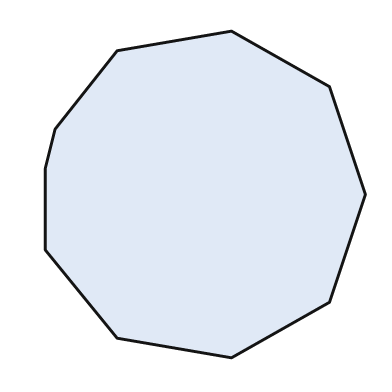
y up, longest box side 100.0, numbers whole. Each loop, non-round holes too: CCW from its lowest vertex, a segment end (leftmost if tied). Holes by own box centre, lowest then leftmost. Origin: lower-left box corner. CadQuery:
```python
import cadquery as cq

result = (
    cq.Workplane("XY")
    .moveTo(57.0, 0.0)
    .lineTo(87.0, 17.0)
    .lineTo(98.0, 50.0)
    .lineTo(87.0, 83.0)
    .lineTo(57.0, 100.0)
    .lineTo(22.0, 94.0)
    .lineTo(3.0, 70.0)
    .lineTo(0.0, 58.0)
    .lineTo(0.0, 33.0)
    .lineTo(22.0, 6.0)
    .close()
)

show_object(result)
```